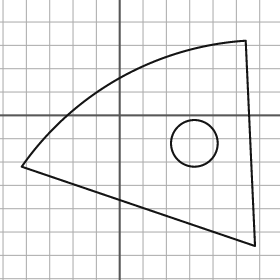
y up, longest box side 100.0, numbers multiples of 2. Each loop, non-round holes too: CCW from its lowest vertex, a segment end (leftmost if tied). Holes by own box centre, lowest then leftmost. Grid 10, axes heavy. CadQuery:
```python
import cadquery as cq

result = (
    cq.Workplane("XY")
    .moveTo(58.0, -56.0)
    .lineTo(54.0, 32.0)
    .threePointArc((0.0, 16.0), (-42.0, -22.0))
    .close()
    .moveTo(32.0, -12.0)
    .circle(10.0)
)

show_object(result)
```